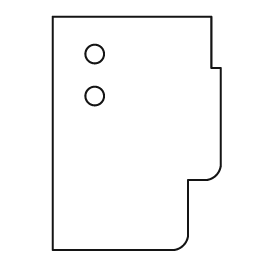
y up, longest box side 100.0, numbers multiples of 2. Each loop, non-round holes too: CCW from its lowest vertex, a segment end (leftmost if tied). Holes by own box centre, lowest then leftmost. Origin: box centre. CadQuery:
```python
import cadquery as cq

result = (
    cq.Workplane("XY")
    .moveTo(-36.0, -50.0)
    .lineTo(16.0, -50.0)
    .threePointArc((20.0, -48.0), (22.0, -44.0))
    .lineTo(22.0, -20.0)
    .lineTo(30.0, -20.0)
    .threePointArc((34.0, -18.0), (36.0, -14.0))
    .lineTo(36.0, 28.0)
    .lineTo(32.0, 28.0)
    .lineTo(32.0, 50.0)
    .lineTo(-36.0, 50.0)
    .close()
    .moveTo(-18.0, 16.0)
    .circle(4.0)
    .moveTo(-18.0, 34.0)
    .circle(4.0)
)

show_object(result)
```